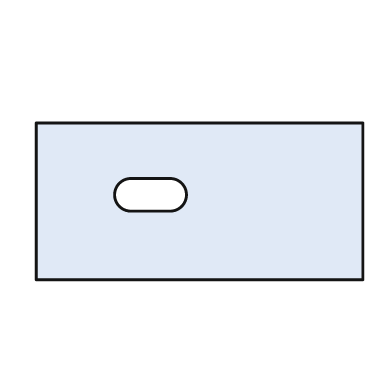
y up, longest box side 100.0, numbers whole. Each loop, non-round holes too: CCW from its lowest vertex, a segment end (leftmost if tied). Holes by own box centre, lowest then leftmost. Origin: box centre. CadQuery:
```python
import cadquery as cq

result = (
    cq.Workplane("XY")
    .moveTo(-50.0, -24.0)
    .lineTo(50.0, -24.0)
    .lineTo(50.0, 24.0)
    .lineTo(-50.0, 24.0)
    .close()
    .moveTo(-21.0, -3.0)
    .lineTo(-9.0, -3.0)
    .threePointArc((-4.0, 2.0), (-9.0, 7.0))
    .lineTo(-21.0, 7.0)
    .threePointArc((-26.0, 2.0), (-21.0, -3.0))
    .close()
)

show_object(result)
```